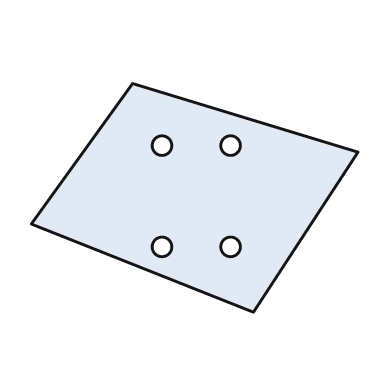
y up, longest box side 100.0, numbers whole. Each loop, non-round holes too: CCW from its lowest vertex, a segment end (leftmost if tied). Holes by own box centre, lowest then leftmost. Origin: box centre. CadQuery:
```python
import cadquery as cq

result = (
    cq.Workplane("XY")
    .moveTo(18.0, -35.0)
    .lineTo(50.0, 14.0)
    .lineTo(-19.0, 35.0)
    .lineTo(-50.0, -8.0)
    .close()
    .moveTo(-10.0, -15.0)
    .circle(3.0)
    .moveTo(11.0, -15.0)
    .circle(3.0)
    .moveTo(-10.0, 16.0)
    .circle(3.0)
    .moveTo(11.0, 16.0)
    .circle(3.0)
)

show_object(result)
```